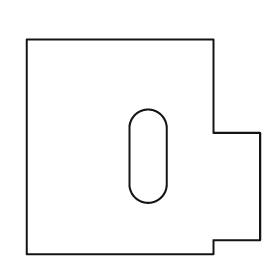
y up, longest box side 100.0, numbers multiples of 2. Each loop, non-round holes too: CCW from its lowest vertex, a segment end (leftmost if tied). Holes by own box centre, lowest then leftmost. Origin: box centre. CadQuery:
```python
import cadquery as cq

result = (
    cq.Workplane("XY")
    .moveTo(-50.0, -46.0)
    .lineTo(30.0, -46.0)
    .lineTo(30.0, -40.0)
    .lineTo(50.0, -40.0)
    .lineTo(50.0, 6.0)
    .lineTo(30.0, 6.0)
    .lineTo(30.0, 46.0)
    .lineTo(-50.0, 46.0)
    .close()
    .moveTo(-6.0, -16.0)
    .threePointArc((2.0, -24.0), (10.0, -16.0))
    .lineTo(10.0, 8.0)
    .threePointArc((2.0, 16.0), (-6.0, 8.0))
    .close()
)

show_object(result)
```